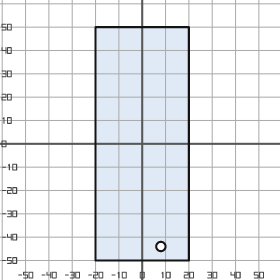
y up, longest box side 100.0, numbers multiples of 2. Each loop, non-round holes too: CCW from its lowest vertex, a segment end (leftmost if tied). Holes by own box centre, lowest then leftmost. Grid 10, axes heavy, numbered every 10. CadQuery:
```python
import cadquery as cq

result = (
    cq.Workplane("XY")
    .moveTo(-20.0, -50.0)
    .lineTo(20.0, -50.0)
    .lineTo(20.0, 50.0)
    .lineTo(-20.0, 50.0)
    .close()
    .moveTo(8.0, -44.0)
    .circle(2.0)
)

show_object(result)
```